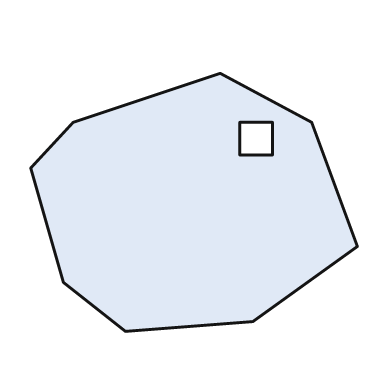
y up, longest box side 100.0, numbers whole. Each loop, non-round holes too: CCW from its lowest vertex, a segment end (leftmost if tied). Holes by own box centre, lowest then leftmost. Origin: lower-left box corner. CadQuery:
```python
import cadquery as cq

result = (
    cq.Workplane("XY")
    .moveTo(29.0, 0.0)
    .lineTo(68.0, 3.0)
    .lineTo(100.0, 26.0)
    .lineTo(86.0, 64.0)
    .lineTo(58.0, 79.0)
    .lineTo(13.0, 64.0)
    .lineTo(0.0, 50.0)
    .lineTo(10.0, 15.0)
    .close()
    .moveTo(64.0, 54.0)
    .lineTo(74.0, 54.0)
    .lineTo(74.0, 64.0)
    .lineTo(64.0, 64.0)
    .close()
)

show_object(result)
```